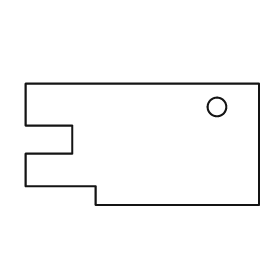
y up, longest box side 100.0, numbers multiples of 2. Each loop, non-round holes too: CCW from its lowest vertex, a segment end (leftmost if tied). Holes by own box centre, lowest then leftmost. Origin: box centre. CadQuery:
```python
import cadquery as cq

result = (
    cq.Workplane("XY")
    .moveTo(-20.0, -26.0)
    .lineTo(50.0, -26.0)
    .lineTo(50.0, 26.0)
    .lineTo(-50.0, 26.0)
    .lineTo(-50.0, 8.0)
    .lineTo(-30.0, 8.0)
    .lineTo(-30.0, -4.0)
    .lineTo(-50.0, -4.0)
    .lineTo(-50.0, -18.0)
    .lineTo(-20.0, -18.0)
    .close()
    .moveTo(32.0, 16.0)
    .circle(4.0)
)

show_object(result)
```